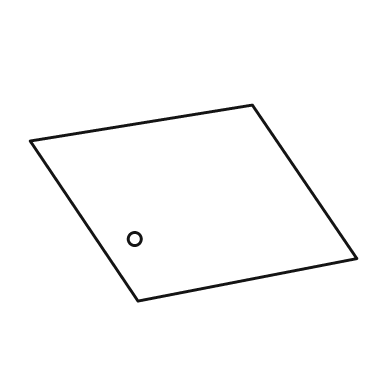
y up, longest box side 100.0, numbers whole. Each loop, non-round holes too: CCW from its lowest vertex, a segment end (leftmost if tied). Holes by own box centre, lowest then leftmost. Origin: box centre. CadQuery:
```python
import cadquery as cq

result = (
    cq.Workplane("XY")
    .moveTo(-17.0, -30.0)
    .lineTo(50.0, -17.0)
    .lineTo(18.0, 30.0)
    .lineTo(-50.0, 19.0)
    .close()
    .moveTo(-18.0, -11.0)
    .circle(2.0)
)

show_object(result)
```